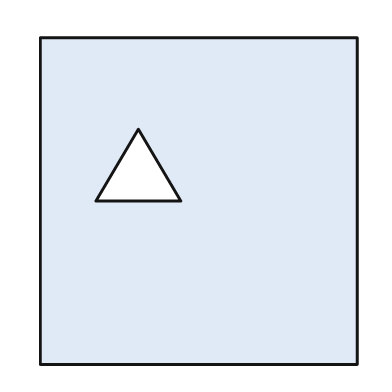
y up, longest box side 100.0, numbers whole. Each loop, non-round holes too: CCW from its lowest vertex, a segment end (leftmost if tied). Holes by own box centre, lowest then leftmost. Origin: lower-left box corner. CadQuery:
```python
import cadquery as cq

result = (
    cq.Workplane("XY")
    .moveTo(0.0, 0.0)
    .lineTo(97.0, 0.0)
    .lineTo(97.0, 100.0)
    .lineTo(0.0, 100.0)
    .close()
    .moveTo(17.0, 50.0)
    .lineTo(43.0, 50.0)
    .lineTo(30.0, 72.0)
    .close()
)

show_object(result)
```